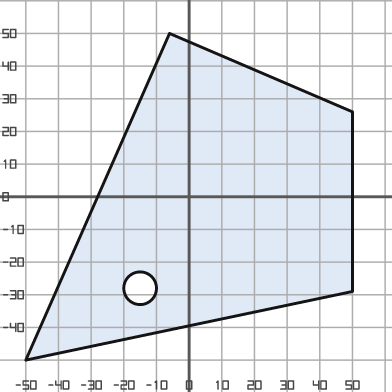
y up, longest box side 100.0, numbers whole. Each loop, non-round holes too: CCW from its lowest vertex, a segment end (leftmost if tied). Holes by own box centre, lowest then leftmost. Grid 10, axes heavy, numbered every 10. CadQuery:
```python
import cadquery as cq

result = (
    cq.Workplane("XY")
    .moveTo(-50.0, -50.0)
    .lineTo(50.0, -29.0)
    .lineTo(50.0, 26.0)
    .lineTo(-6.0, 50.0)
    .close()
    .moveTo(-15.0, -28.0)
    .circle(5.0)
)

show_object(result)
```